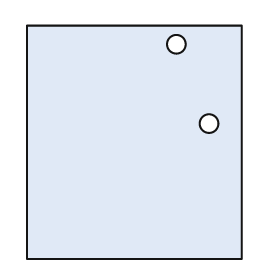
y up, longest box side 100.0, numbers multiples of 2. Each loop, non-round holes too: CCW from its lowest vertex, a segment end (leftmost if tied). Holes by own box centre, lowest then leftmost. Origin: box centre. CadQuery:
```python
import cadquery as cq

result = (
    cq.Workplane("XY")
    .moveTo(-46.0, -50.0)
    .lineTo(46.0, -50.0)
    .lineTo(46.0, 50.0)
    .lineTo(-46.0, 50.0)
    .close()
    .moveTo(32.0, 8.0)
    .circle(4.0)
    .moveTo(18.0, 42.0)
    .circle(4.0)
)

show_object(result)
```